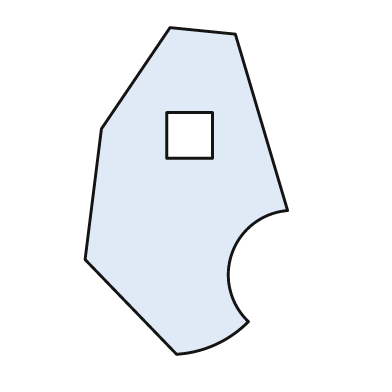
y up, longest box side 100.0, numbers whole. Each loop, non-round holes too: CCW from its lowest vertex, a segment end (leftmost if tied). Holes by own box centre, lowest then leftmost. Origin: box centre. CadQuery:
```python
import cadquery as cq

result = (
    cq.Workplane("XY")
    .moveTo(-3.0, -50.0)
    .threePointArc((9.0, -47.0), (19.0, -40.0))
    .threePointArc((14.0, -19.0), (31.0, -6.0))
    .lineTo(15.0, 48.0)
    .lineTo(-5.0, 50.0)
    .lineTo(-26.0, 19.0)
    .lineTo(-31.0, -21.0)
    .close()
    .moveTo(-6.0, 10.0)
    .lineTo(8.0, 10.0)
    .lineTo(8.0, 24.0)
    .lineTo(-6.0, 24.0)
    .close()
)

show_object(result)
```